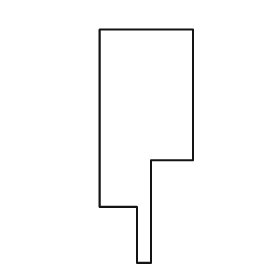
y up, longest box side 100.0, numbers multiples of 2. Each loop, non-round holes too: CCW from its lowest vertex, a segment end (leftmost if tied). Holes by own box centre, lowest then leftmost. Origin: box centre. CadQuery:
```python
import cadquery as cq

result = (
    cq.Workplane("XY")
    .moveTo(-4.0, -50.0)
    .lineTo(2.0, -50.0)
    .lineTo(2.0, -6.0)
    .lineTo(20.0, -6.0)
    .lineTo(20.0, 50.0)
    .lineTo(-20.0, 50.0)
    .lineTo(-20.0, -26.0)
    .lineTo(-4.0, -26.0)
    .close()
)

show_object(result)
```